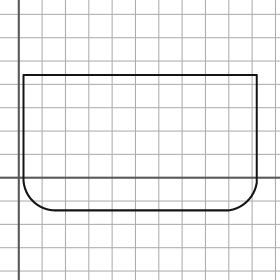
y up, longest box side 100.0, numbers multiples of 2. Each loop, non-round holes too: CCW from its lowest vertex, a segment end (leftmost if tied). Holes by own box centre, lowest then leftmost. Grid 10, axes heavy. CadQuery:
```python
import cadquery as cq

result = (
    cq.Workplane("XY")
    .moveTo(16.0, -14.0)
    .lineTo(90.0, -14.0)
    .threePointArc((98.0, -10.0), (102.0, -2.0))
    .lineTo(102.0, 44.0)
    .lineTo(2.0, 44.0)
    .lineTo(2.0, 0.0)
    .threePointArc((6.0, -10.0), (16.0, -14.0))
    .close()
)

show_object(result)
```